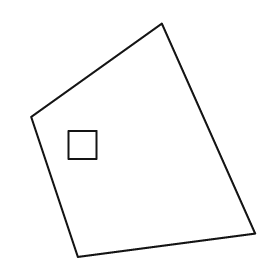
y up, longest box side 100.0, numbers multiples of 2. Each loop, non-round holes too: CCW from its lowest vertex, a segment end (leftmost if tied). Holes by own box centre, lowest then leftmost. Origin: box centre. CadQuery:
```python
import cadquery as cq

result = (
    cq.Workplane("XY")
    .moveTo(-28.0, -50.0)
    .lineTo(48.0, -40.0)
    .lineTo(8.0, 50.0)
    .lineTo(-48.0, 10.0)
    .close()
    .moveTo(-32.0, -8.0)
    .lineTo(-20.0, -8.0)
    .lineTo(-20.0, 4.0)
    .lineTo(-32.0, 4.0)
    .close()
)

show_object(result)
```